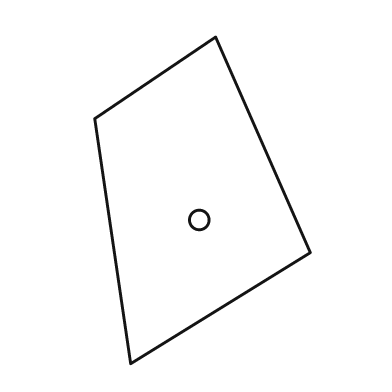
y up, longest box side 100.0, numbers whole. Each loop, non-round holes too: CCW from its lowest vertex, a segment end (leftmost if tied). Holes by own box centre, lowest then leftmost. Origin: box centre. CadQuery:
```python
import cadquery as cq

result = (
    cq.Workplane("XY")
    .moveTo(-22.0, -50.0)
    .lineTo(33.0, -16.0)
    .lineTo(4.0, 50.0)
    .lineTo(-33.0, 25.0)
    .close()
    .moveTo(-1.0, -6.0)
    .circle(3.0)
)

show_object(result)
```